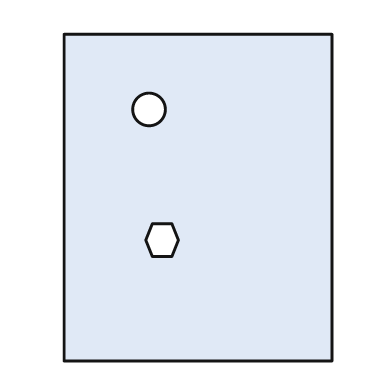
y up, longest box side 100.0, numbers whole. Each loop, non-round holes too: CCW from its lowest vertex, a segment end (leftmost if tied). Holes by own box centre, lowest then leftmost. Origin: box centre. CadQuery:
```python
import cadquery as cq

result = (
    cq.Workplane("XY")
    .moveTo(-41.0, -50.0)
    .lineTo(41.0, -50.0)
    .lineTo(41.0, 50.0)
    .lineTo(-41.0, 50.0)
    .close()
    .moveTo(-14.0, -18.0)
    .lineTo(-8.0, -18.0)
    .lineTo(-6.0, -13.0)
    .lineTo(-8.0, -8.0)
    .lineTo(-14.0, -8.0)
    .lineTo(-16.0, -13.0)
    .close()
    .moveTo(-15.0, 27.0)
    .circle(5.0)
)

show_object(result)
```